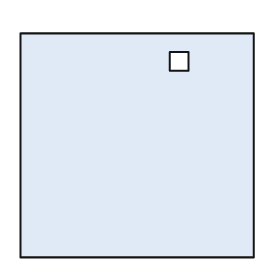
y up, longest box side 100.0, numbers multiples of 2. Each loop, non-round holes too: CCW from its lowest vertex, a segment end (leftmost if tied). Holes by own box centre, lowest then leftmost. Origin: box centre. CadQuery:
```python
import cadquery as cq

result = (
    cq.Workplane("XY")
    .moveTo(-50.0, -48.0)
    .lineTo(50.0, -48.0)
    .lineTo(50.0, 48.0)
    .lineTo(-50.0, 48.0)
    .close()
    .moveTo(14.0, 32.0)
    .lineTo(22.0, 32.0)
    .lineTo(22.0, 40.0)
    .lineTo(14.0, 40.0)
    .close()
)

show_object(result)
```